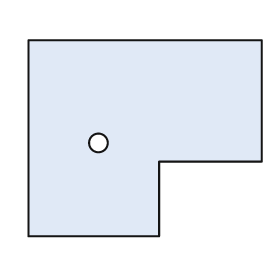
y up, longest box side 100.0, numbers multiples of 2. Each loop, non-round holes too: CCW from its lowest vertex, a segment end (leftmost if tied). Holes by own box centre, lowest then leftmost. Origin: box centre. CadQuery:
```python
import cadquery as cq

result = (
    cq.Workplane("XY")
    .moveTo(-50.0, -42.0)
    .lineTo(6.0, -42.0)
    .lineTo(6.0, -10.0)
    .lineTo(50.0, -10.0)
    .lineTo(50.0, 42.0)
    .lineTo(-50.0, 42.0)
    .close()
    .moveTo(-20.0, -2.0)
    .circle(4.0)
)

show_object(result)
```